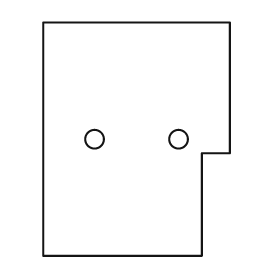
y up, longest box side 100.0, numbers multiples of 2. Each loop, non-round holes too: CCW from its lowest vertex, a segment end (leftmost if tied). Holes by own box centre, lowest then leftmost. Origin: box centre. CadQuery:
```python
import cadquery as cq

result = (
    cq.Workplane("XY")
    .moveTo(-40.0, -50.0)
    .lineTo(28.0, -50.0)
    .lineTo(28.0, -6.0)
    .lineTo(40.0, -6.0)
    .lineTo(40.0, 50.0)
    .lineTo(-40.0, 50.0)
    .close()
    .moveTo(-18.0, 0.0)
    .circle(4.0)
    .moveTo(18.0, 0.0)
    .circle(4.0)
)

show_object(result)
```